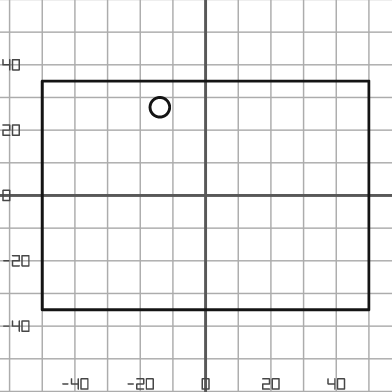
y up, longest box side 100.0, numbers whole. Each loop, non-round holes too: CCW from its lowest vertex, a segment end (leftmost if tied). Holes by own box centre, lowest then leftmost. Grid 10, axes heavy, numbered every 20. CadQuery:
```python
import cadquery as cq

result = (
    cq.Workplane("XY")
    .moveTo(-50.0, -35.0)
    .lineTo(50.0, -35.0)
    .lineTo(50.0, 35.0)
    .lineTo(-50.0, 35.0)
    .close()
    .moveTo(-14.0, 27.0)
    .circle(3.0)
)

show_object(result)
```